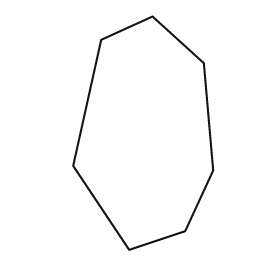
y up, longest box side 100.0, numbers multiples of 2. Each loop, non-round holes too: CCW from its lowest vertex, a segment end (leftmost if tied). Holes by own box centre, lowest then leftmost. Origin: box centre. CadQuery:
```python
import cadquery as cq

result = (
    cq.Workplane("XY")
    .moveTo(-6.0, -50.0)
    .lineTo(18.0, -42.0)
    .lineTo(30.0, -16.0)
    .lineTo(26.0, 30.0)
    .lineTo(4.0, 50.0)
    .lineTo(-18.0, 40.0)
    .lineTo(-30.0, -14.0)
    .close()
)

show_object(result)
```